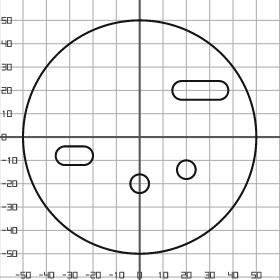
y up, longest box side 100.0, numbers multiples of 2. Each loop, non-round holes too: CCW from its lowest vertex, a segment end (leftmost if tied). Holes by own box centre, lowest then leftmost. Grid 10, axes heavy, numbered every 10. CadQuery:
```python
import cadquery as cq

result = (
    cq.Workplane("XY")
    .moveTo(0.0, 0.0)
    .circle(50.0)
    .moveTo(0.0, -20.0)
    .circle(4.0)
    .moveTo(20.0, -14.0)
    .circle(4.0)
    .moveTo(-32.0, -12.0)
    .lineTo(-24.0, -12.0)
    .threePointArc((-20.0, -8.0), (-24.0, -4.0))
    .lineTo(-32.0, -4.0)
    .threePointArc((-36.0, -8.0), (-32.0, -12.0))
    .close()
    .moveTo(18.0, 16.0)
    .lineTo(34.0, 16.0)
    .threePointArc((38.0, 20.0), (34.0, 24.0))
    .lineTo(18.0, 24.0)
    .threePointArc((14.0, 20.0), (18.0, 16.0))
    .close()
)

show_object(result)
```